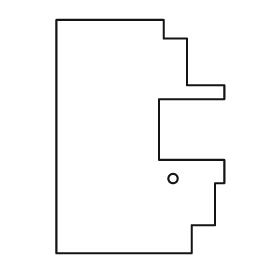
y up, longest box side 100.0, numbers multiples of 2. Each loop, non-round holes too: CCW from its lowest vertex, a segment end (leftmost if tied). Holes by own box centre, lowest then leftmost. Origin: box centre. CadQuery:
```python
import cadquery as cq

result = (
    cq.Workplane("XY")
    .moveTo(-36.0, -50.0)
    .lineTo(22.0, -50.0)
    .lineTo(22.0, -38.0)
    .lineTo(32.0, -38.0)
    .lineTo(32.0, -20.0)
    .lineTo(36.0, -20.0)
    .lineTo(36.0, -10.0)
    .lineTo(8.0, -10.0)
    .lineTo(8.0, 16.0)
    .lineTo(36.0, 16.0)
    .lineTo(36.0, 22.0)
    .lineTo(20.0, 22.0)
    .lineTo(20.0, 42.0)
    .lineTo(10.0, 42.0)
    .lineTo(10.0, 50.0)
    .lineTo(-36.0, 50.0)
    .close()
    .moveTo(14.0, -18.0)
    .circle(2.0)
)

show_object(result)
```